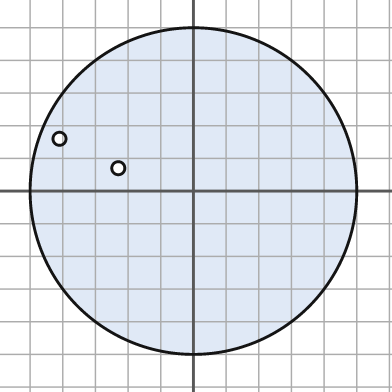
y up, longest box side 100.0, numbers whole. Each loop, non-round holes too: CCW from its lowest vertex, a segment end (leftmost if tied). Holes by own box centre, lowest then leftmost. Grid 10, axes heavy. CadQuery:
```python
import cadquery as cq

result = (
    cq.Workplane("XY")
    .moveTo(0.0, 0.0)
    .circle(50.0)
    .moveTo(-23.0, 7.0)
    .circle(2.0)
    .moveTo(-41.0, 16.0)
    .circle(2.0)
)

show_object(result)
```